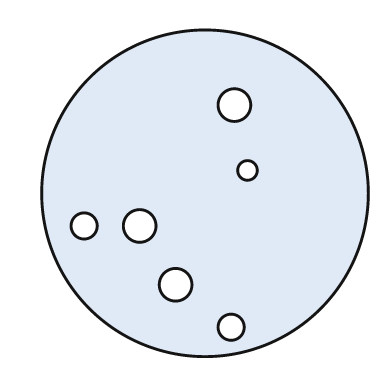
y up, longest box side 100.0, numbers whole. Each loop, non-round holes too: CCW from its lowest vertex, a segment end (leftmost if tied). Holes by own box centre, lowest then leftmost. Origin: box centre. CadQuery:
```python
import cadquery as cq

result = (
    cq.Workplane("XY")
    .moveTo(0.0, 0.0)
    .circle(50.0)
    .moveTo(8.0, -41.0)
    .circle(4.0)
    .moveTo(-9.0, -28.0)
    .circle(5.0)
    .moveTo(-37.0, -10.0)
    .circle(4.0)
    .moveTo(-20.0, -10.0)
    .circle(5.0)
    .moveTo(13.0, 7.0)
    .circle(3.0)
    .moveTo(9.0, 27.0)
    .circle(5.0)
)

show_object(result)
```